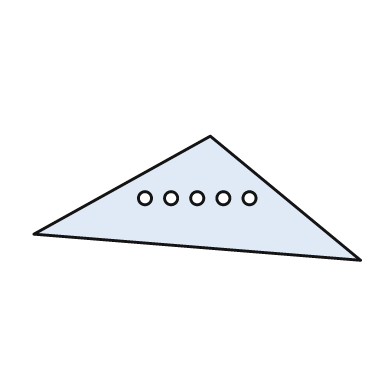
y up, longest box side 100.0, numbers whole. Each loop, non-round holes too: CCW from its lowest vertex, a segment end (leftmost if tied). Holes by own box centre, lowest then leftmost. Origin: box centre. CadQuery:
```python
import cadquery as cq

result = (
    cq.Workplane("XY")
    .moveTo(50.0, -19.0)
    .lineTo(4.0, 19.0)
    .lineTo(-50.0, -11.0)
    .close()
    .moveTo(-16.0, 0.0)
    .circle(2.0)
    .moveTo(-8.0, 0.0)
    .circle(2.0)
    .moveTo(0.0, 0.0)
    .circle(2.0)
    .moveTo(8.0, 0.0)
    .circle(2.0)
    .moveTo(16.0, 0.0)
    .circle(2.0)
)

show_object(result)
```